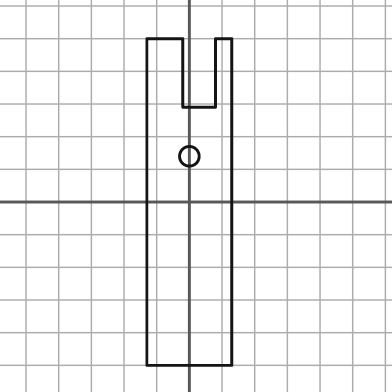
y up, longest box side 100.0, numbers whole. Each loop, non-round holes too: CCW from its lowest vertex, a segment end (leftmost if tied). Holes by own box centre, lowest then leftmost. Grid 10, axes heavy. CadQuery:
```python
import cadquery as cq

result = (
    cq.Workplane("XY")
    .moveTo(-13.0, -50.0)
    .lineTo(13.0, -50.0)
    .lineTo(13.0, 50.0)
    .lineTo(8.0, 50.0)
    .lineTo(8.0, 29.0)
    .lineTo(-2.0, 29.0)
    .lineTo(-2.0, 50.0)
    .lineTo(-13.0, 50.0)
    .close()
    .moveTo(0.0, 14.0)
    .circle(3.0)
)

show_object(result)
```